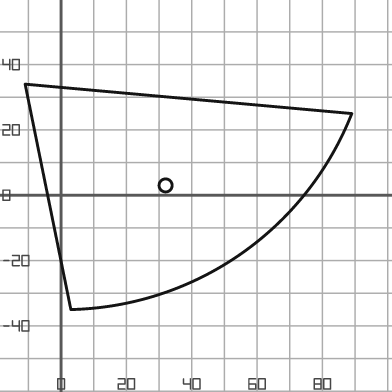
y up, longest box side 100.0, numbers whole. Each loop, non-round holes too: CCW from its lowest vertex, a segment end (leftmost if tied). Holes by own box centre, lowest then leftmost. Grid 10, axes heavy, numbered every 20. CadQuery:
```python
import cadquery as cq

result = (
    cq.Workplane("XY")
    .moveTo(3.0, -35.0)
    .threePointArc((55.0, -18.0), (89.0, 25.0))
    .lineTo(-11.0, 34.0)
    .close()
    .moveTo(32.0, 3.0)
    .circle(2.0)
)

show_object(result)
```